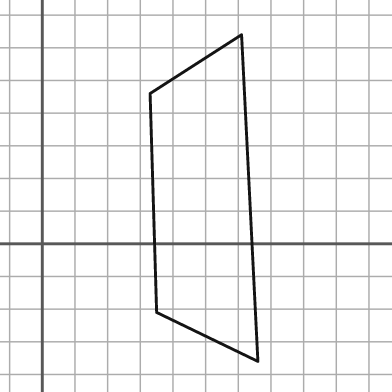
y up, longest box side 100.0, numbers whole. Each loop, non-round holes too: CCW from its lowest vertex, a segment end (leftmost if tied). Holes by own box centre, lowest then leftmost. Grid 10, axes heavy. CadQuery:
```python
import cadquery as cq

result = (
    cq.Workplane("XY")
    .moveTo(66.0, -36.0)
    .lineTo(61.0, 64.0)
    .lineTo(33.0, 46.0)
    .lineTo(35.0, -21.0)
    .close()
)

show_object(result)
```